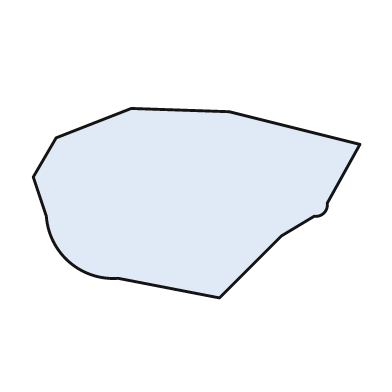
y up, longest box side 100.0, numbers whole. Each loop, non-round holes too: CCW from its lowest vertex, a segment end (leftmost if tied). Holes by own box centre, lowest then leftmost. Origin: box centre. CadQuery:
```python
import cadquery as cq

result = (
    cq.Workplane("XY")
    .moveTo(7.0, -29.0)
    .lineTo(26.0, -10.0)
    .lineTo(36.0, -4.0)
    .threePointArc((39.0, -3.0), (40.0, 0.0))
    .lineTo(50.0, 18.0)
    .lineTo(10.0, 28.0)
    .lineTo(-20.0, 29.0)
    .lineTo(-43.0, 20.0)
    .lineTo(-50.0, 8.0)
    .lineTo(-46.0, -4.0)
    .threePointArc((-39.0, -18.0), (-24.0, -23.0))
    .close()
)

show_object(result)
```